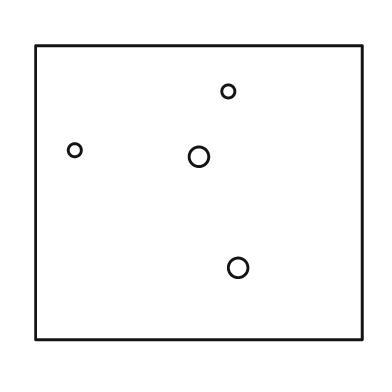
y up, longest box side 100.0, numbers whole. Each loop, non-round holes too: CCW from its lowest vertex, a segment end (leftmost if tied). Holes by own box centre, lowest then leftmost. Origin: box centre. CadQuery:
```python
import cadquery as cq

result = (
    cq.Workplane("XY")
    .moveTo(-50.0, -45.0)
    .lineTo(50.0, -45.0)
    .lineTo(50.0, 45.0)
    .lineTo(-50.0, 45.0)
    .close()
    .moveTo(12.0, -23.0)
    .circle(3.0)
    .moveTo(0.0, 11.0)
    .circle(3.0)
    .moveTo(-38.0, 13.0)
    .circle(2.0)
    .moveTo(9.0, 31.0)
    .circle(2.0)
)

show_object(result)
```